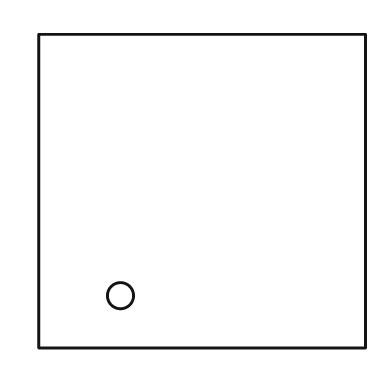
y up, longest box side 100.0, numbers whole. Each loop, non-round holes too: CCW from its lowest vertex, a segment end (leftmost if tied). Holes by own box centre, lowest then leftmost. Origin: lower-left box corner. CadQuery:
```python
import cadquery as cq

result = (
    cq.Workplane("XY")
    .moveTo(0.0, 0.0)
    .lineTo(100.0, 0.0)
    .lineTo(100.0, 96.0)
    .lineTo(0.0, 96.0)
    .close()
    .moveTo(25.0, 16.0)
    .circle(4.0)
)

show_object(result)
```